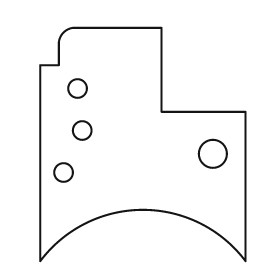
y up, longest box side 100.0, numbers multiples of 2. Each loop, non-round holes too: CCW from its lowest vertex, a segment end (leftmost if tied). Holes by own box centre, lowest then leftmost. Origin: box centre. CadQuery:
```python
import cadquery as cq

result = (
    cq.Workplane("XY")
    .moveTo(-44.0, -50.0)
    .threePointArc((0.0, -28.0), (44.0, -50.0))
    .lineTo(44.0, 14.0)
    .lineTo(8.0, 14.0)
    .lineTo(8.0, 50.0)
    .lineTo(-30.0, 50.0)
    .threePointArc((-34.0, 48.0), (-36.0, 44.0))
    .lineTo(-36.0, 34.0)
    .lineTo(-44.0, 34.0)
    .close()
    .moveTo(-34.0, -12.0)
    .circle(4.0)
    .moveTo(30.0, -4.0)
    .circle(6.0)
    .moveTo(-26.0, 6.0)
    .circle(4.0)
    .moveTo(-28.0, 24.0)
    .circle(4.0)
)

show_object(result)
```